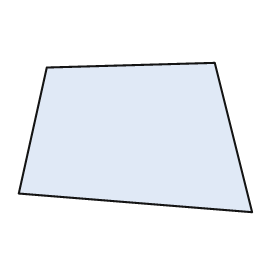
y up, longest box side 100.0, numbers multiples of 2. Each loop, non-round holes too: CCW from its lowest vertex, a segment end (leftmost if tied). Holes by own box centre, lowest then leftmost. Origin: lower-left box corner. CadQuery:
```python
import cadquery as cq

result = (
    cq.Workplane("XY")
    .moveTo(100.0, 0.0)
    .lineTo(84.0, 64.0)
    .lineTo(12.0, 62.0)
    .lineTo(0.0, 8.0)
    .close()
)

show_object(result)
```